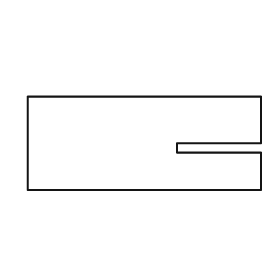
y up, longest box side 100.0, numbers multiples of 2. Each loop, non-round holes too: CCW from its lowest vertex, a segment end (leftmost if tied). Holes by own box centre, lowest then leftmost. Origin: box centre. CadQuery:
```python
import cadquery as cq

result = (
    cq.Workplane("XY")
    .moveTo(-50.0, -20.0)
    .lineTo(50.0, -20.0)
    .lineTo(50.0, -4.0)
    .lineTo(14.0, -4.0)
    .lineTo(14.0, 0.0)
    .lineTo(50.0, 0.0)
    .lineTo(50.0, 20.0)
    .lineTo(-50.0, 20.0)
    .close()
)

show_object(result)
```